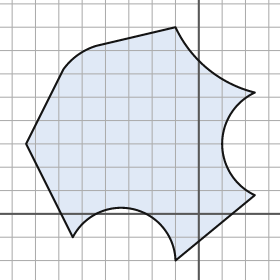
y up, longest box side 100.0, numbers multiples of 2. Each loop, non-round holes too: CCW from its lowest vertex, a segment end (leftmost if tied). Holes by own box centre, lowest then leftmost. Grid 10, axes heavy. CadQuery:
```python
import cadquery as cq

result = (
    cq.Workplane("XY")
    .moveTo(-10.0, -20.0)
    .lineTo(24.0, 8.0)
    .threePointArc((10.0, 30.0), (24.0, 52.0))
    .threePointArc((4.0, 62.0), (-10.0, 80.0))
    .lineTo(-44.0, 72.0)
    .threePointArc((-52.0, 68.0), (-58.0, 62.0))
    .lineTo(-74.0, 30.0)
    .lineTo(-54.0, -10.0)
    .threePointArc((-28.0, 2.0), (-10.0, -20.0))
    .close()
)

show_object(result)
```